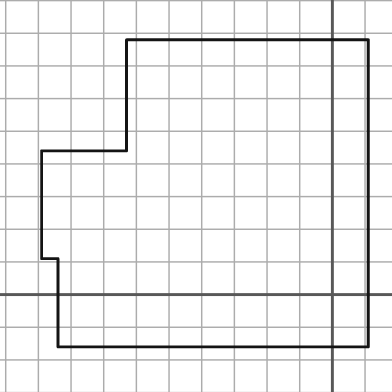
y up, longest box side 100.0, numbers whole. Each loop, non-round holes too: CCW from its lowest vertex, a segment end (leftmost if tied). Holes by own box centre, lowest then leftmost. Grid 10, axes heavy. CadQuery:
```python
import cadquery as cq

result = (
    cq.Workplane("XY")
    .moveTo(-84.0, -16.0)
    .lineTo(11.0, -16.0)
    .lineTo(11.0, 78.0)
    .lineTo(-63.0, 78.0)
    .lineTo(-63.0, 44.0)
    .lineTo(-89.0, 44.0)
    .lineTo(-89.0, 11.0)
    .lineTo(-84.0, 11.0)
    .close()
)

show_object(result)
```